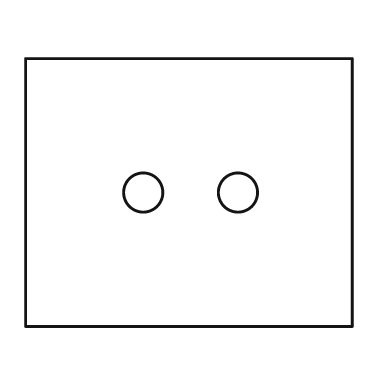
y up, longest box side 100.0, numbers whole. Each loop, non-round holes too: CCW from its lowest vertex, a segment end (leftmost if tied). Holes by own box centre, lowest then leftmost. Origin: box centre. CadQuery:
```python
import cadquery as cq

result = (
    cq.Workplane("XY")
    .moveTo(-50.0, -41.0)
    .lineTo(50.0, -41.0)
    .lineTo(50.0, 41.0)
    .lineTo(-50.0, 41.0)
    .close()
    .moveTo(-14.0, 0.0)
    .circle(6.0)
    .moveTo(15.0, 0.0)
    .circle(6.0)
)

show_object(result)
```